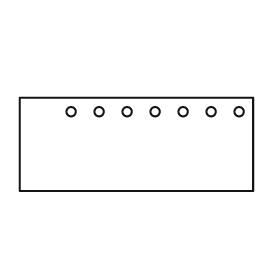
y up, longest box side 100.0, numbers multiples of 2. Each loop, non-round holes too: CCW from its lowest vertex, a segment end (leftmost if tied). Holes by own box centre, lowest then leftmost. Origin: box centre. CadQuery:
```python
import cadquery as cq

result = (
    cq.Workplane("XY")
    .moveTo(-50.0, -20.0)
    .lineTo(50.0, -20.0)
    .lineTo(50.0, 20.0)
    .lineTo(-50.0, 20.0)
    .close()
    .moveTo(-28.0, 14.0)
    .circle(2.0)
    .moveTo(-16.0, 14.0)
    .circle(2.0)
    .moveTo(-4.0, 14.0)
    .circle(2.0)
    .moveTo(8.0, 14.0)
    .circle(2.0)
    .moveTo(20.0, 14.0)
    .circle(2.0)
    .moveTo(32.0, 14.0)
    .circle(2.0)
    .moveTo(44.0, 14.0)
    .circle(2.0)
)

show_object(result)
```